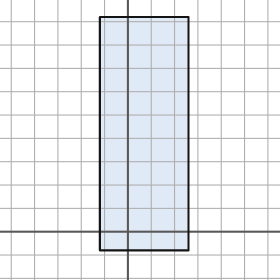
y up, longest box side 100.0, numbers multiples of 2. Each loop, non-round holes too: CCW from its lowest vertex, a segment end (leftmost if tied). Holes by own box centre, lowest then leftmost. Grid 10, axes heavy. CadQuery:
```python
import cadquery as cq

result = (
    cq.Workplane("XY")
    .moveTo(-12.0, -8.0)
    .lineTo(26.0, -8.0)
    .lineTo(26.0, 92.0)
    .lineTo(-12.0, 92.0)
    .close()
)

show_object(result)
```